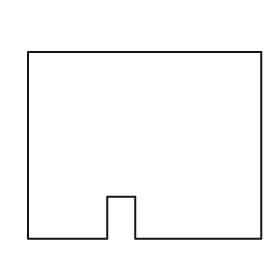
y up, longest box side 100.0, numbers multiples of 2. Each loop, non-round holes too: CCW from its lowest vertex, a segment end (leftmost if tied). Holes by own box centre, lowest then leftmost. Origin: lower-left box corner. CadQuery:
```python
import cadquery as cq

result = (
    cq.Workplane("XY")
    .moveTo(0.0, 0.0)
    .lineTo(34.0, 0.0)
    .lineTo(34.0, 18.0)
    .lineTo(46.0, 18.0)
    .lineTo(46.0, 0.0)
    .lineTo(100.0, 0.0)
    .lineTo(100.0, 80.0)
    .lineTo(0.0, 80.0)
    .close()
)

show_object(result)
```